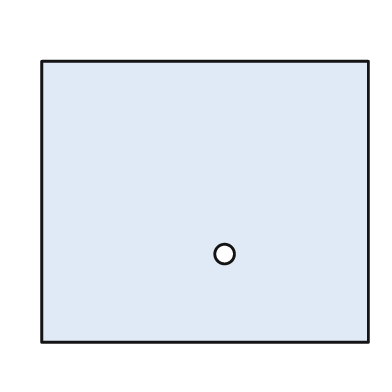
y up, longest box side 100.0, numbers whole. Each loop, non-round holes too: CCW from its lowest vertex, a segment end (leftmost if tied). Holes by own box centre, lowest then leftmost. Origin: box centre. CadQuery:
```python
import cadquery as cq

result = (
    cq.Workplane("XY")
    .moveTo(-50.0, -43.0)
    .lineTo(50.0, -43.0)
    .lineTo(50.0, 43.0)
    .lineTo(-50.0, 43.0)
    .close()
    .moveTo(6.0, -16.0)
    .circle(3.0)
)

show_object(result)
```